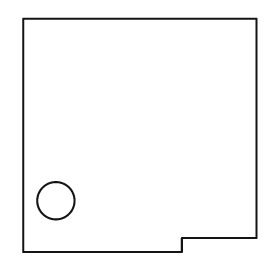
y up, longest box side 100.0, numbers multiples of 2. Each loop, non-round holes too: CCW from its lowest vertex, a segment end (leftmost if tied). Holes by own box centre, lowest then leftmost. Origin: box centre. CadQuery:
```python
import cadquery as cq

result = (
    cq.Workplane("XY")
    .moveTo(-50.0, -50.0)
    .lineTo(18.0, -50.0)
    .lineTo(18.0, -44.0)
    .lineTo(50.0, -44.0)
    .lineTo(50.0, 50.0)
    .lineTo(-50.0, 50.0)
    .close()
    .moveTo(-36.0, -28.0)
    .circle(8.0)
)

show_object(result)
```